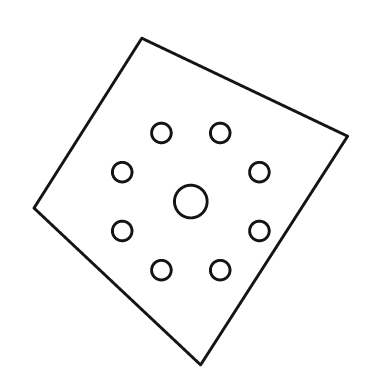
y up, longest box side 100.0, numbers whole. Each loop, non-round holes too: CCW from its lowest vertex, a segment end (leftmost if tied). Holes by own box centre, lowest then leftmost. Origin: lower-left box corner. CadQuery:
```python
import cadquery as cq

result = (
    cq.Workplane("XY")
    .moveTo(51.0, 0.0)
    .lineTo(96.0, 70.0)
    .lineTo(33.0, 100.0)
    .lineTo(0.0, 48.0)
    .close()
    .moveTo(39.0, 29.0)
    .circle(3.0)
    .moveTo(57.0, 29.0)
    .circle(3.0)
    .moveTo(27.0, 41.0)
    .circle(3.0)
    .moveTo(69.0, 41.0)
    .circle(3.0)
    .moveTo(48.0, 50.0)
    .circle(5.0)
    .moveTo(27.0, 59.0)
    .circle(3.0)
    .moveTo(69.0, 59.0)
    .circle(3.0)
    .moveTo(39.0, 71.0)
    .circle(3.0)
    .moveTo(57.0, 71.0)
    .circle(3.0)
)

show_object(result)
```